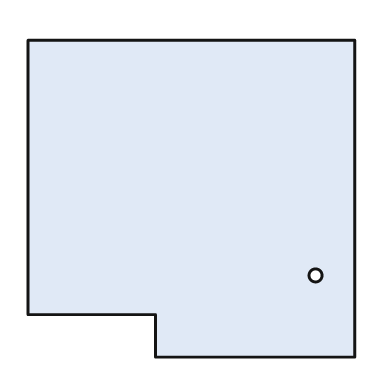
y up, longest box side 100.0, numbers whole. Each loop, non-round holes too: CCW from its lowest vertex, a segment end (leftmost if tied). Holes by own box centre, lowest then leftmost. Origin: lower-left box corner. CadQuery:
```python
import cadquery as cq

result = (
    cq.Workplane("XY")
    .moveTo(39.0, 0.0)
    .lineTo(100.0, 0.0)
    .lineTo(100.0, 97.0)
    .lineTo(0.0, 97.0)
    .lineTo(0.0, 13.0)
    .lineTo(39.0, 13.0)
    .close()
    .moveTo(88.0, 25.0)
    .circle(2.0)
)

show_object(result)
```